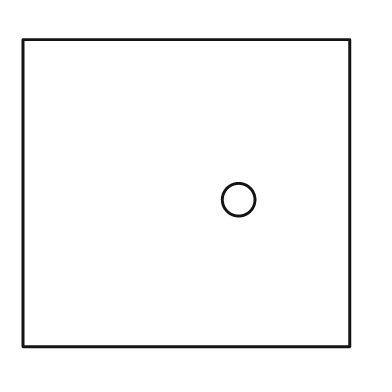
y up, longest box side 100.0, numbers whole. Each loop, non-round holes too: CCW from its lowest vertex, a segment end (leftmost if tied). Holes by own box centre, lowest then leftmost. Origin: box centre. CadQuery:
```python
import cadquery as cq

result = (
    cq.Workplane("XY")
    .moveTo(-50.0, -47.0)
    .lineTo(50.0, -47.0)
    .lineTo(50.0, 47.0)
    .lineTo(-50.0, 47.0)
    .close()
    .moveTo(16.0, -2.0)
    .circle(5.0)
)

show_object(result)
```